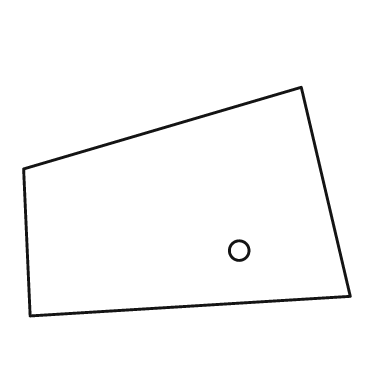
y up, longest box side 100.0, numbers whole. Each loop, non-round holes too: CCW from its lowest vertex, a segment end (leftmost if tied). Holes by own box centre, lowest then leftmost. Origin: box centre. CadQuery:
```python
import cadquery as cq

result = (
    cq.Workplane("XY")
    .moveTo(-48.0, -35.0)
    .lineTo(50.0, -29.0)
    .lineTo(35.0, 35.0)
    .lineTo(-50.0, 10.0)
    .close()
    .moveTo(16.0, -15.0)
    .circle(3.0)
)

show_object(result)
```